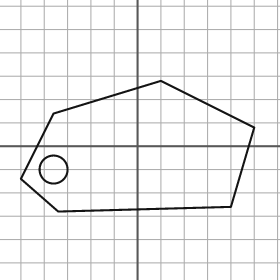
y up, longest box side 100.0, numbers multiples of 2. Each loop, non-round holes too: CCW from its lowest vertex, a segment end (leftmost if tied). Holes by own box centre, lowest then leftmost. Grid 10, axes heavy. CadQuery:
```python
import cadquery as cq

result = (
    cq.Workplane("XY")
    .moveTo(-34.0, -28.0)
    .lineTo(40.0, -26.0)
    .lineTo(50.0, 8.0)
    .lineTo(10.0, 28.0)
    .lineTo(-36.0, 14.0)
    .lineTo(-50.0, -14.0)
    .close()
    .moveTo(-36.0, -10.0)
    .circle(6.0)
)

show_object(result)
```